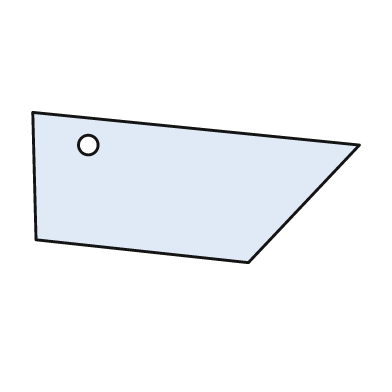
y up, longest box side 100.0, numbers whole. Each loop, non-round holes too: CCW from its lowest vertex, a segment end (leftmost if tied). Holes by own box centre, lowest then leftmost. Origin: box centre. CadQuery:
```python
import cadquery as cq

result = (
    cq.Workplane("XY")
    .moveTo(16.0, -23.0)
    .lineTo(50.0, 13.0)
    .lineTo(-50.0, 23.0)
    .lineTo(-49.0, -16.0)
    .close()
    .moveTo(-33.0, 13.0)
    .circle(3.0)
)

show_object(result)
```